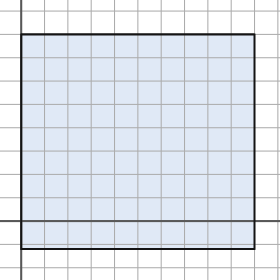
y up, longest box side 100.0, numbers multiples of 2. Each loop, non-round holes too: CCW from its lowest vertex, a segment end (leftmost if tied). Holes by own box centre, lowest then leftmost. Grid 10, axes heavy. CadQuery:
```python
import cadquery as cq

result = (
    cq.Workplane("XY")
    .moveTo(0.0, -12.0)
    .lineTo(100.0, -12.0)
    .lineTo(100.0, 80.0)
    .lineTo(0.0, 80.0)
    .close()
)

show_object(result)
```